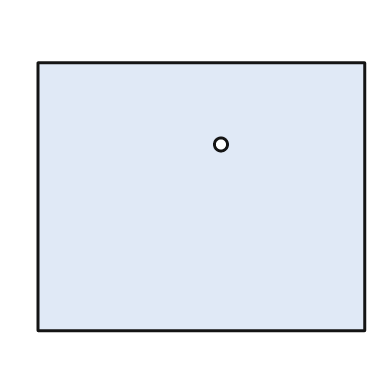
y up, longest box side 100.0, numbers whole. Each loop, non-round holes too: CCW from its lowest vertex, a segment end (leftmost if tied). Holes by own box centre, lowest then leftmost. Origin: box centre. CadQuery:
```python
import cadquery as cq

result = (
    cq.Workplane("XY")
    .moveTo(-50.0, -41.0)
    .lineTo(50.0, -41.0)
    .lineTo(50.0, 41.0)
    .lineTo(-50.0, 41.0)
    .close()
    .moveTo(6.0, 16.0)
    .circle(2.0)
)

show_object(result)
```